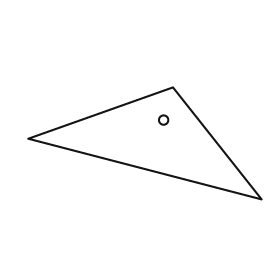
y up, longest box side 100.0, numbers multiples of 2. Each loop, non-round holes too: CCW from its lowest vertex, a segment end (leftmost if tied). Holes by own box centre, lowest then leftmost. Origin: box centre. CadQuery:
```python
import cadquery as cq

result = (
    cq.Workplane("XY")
    .moveTo(50.0, -24.0)
    .lineTo(12.0, 24.0)
    .lineTo(-50.0, 2.0)
    .close()
    .moveTo(8.0, 10.0)
    .circle(2.0)
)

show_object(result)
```